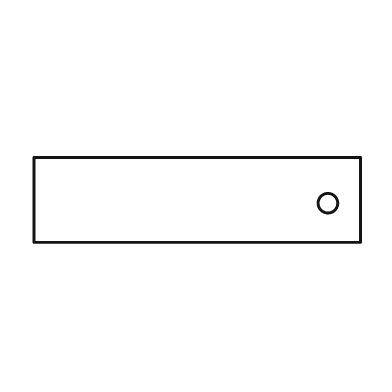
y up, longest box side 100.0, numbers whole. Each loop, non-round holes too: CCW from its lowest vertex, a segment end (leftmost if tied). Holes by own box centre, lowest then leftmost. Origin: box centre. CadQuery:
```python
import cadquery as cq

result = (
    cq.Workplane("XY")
    .moveTo(-50.0, -13.0)
    .lineTo(50.0, -13.0)
    .lineTo(50.0, 13.0)
    .lineTo(-50.0, 13.0)
    .close()
    .moveTo(40.0, -1.0)
    .circle(3.0)
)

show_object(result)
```